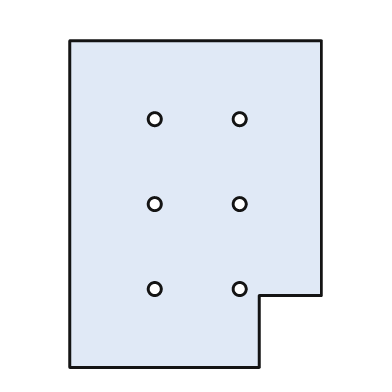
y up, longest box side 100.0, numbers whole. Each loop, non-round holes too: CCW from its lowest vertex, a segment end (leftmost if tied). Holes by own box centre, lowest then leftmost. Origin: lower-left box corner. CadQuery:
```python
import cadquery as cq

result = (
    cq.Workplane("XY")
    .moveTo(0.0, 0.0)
    .lineTo(58.0, 0.0)
    .lineTo(58.0, 22.0)
    .lineTo(77.0, 22.0)
    .lineTo(77.0, 100.0)
    .lineTo(0.0, 100.0)
    .close()
    .moveTo(26.0, 24.0)
    .circle(2.0)
    .moveTo(52.0, 24.0)
    .circle(2.0)
    .moveTo(26.0, 50.0)
    .circle(2.0)
    .moveTo(52.0, 50.0)
    .circle(2.0)
    .moveTo(26.0, 76.0)
    .circle(2.0)
    .moveTo(52.0, 76.0)
    .circle(2.0)
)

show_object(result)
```